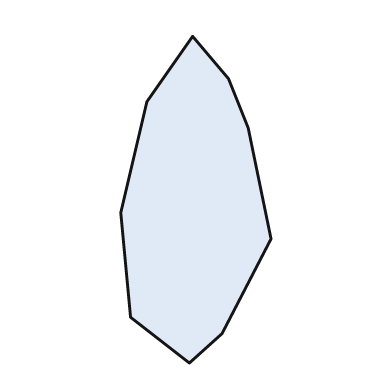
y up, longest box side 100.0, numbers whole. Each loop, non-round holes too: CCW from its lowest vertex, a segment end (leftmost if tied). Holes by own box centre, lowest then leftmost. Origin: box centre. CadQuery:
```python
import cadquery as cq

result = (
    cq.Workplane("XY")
    .moveTo(-2.0, -50.0)
    .lineTo(8.0, -41.0)
    .lineTo(23.0, -12.0)
    .lineTo(16.0, 22.0)
    .lineTo(10.0, 37.0)
    .lineTo(-1.0, 50.0)
    .lineTo(-15.0, 30.0)
    .lineTo(-23.0, -4.0)
    .lineTo(-20.0, -36.0)
    .close()
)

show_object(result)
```